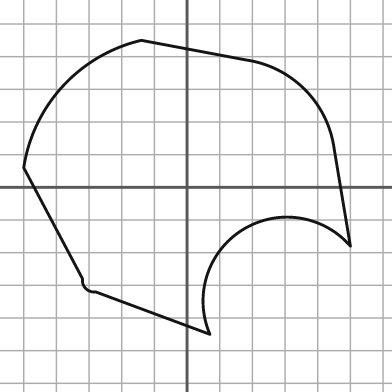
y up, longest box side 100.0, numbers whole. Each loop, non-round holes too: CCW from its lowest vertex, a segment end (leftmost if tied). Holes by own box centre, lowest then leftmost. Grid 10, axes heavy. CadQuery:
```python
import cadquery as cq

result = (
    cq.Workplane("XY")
    .moveTo(7.0, -45.0)
    .threePointArc((17.0, -13.0), (50.0, -18.0))
    .lineTo(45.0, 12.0)
    .threePointArc((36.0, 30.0), (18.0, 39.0))
    .lineTo(-14.0, 45.0)
    .threePointArc((-38.0, 31.0), (-50.0, 6.0))
    .lineTo(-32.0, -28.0)
    .threePointArc((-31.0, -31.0), (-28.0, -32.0))
    .close()
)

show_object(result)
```